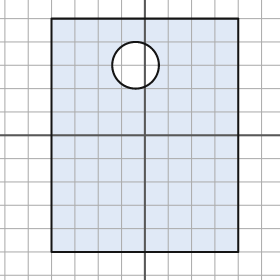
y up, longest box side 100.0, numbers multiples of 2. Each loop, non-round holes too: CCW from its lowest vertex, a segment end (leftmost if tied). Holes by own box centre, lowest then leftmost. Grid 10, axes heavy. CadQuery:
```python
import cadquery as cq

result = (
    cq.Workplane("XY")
    .moveTo(-40.0, -50.0)
    .lineTo(40.0, -50.0)
    .lineTo(40.0, 50.0)
    .lineTo(-40.0, 50.0)
    .close()
    .moveTo(-4.0, 30.0)
    .circle(10.0)
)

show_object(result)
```